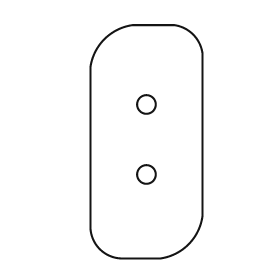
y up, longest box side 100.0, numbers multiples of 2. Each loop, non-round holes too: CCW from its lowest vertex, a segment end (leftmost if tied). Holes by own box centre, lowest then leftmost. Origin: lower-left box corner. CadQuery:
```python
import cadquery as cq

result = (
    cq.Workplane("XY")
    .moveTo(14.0, 0.0)
    .lineTo(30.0, 0.0)
    .threePointArc((42.0, 6.0), (48.0, 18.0))
    .lineTo(48.0, 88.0)
    .threePointArc((44.0, 96.0), (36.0, 100.0))
    .lineTo(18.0, 100.0)
    .threePointArc((6.0, 94.0), (0.0, 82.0))
    .lineTo(0.0, 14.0)
    .threePointArc((4.0, 4.0), (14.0, 0.0))
    .close()
    .moveTo(24.0, 36.0)
    .circle(4.0)
    .moveTo(24.0, 66.0)
    .circle(4.0)
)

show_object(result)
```